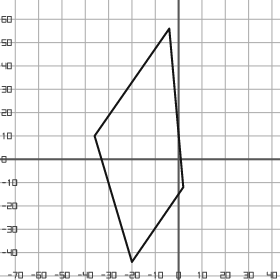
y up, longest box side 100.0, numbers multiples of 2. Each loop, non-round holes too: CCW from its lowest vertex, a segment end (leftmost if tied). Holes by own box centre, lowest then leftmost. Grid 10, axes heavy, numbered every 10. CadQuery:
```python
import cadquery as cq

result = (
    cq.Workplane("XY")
    .moveTo(-20.0, -44.0)
    .lineTo(2.0, -12.0)
    .lineTo(-4.0, 56.0)
    .lineTo(-36.0, 10.0)
    .close()
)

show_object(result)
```